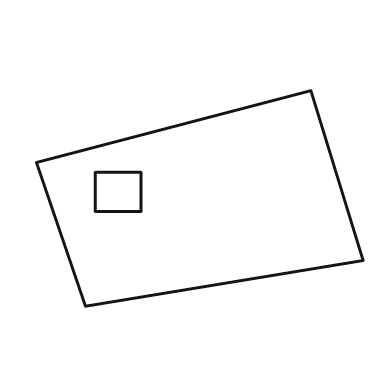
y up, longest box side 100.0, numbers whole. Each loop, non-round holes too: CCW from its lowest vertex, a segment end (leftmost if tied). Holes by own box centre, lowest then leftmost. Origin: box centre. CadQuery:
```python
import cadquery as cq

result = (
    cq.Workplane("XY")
    .moveTo(-35.0, -33.0)
    .lineTo(50.0, -19.0)
    .lineTo(34.0, 33.0)
    .lineTo(-50.0, 11.0)
    .close()
    .moveTo(-32.0, -4.0)
    .lineTo(-18.0, -4.0)
    .lineTo(-18.0, 8.0)
    .lineTo(-32.0, 8.0)
    .close()
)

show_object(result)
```